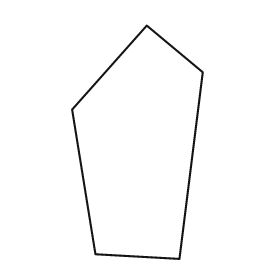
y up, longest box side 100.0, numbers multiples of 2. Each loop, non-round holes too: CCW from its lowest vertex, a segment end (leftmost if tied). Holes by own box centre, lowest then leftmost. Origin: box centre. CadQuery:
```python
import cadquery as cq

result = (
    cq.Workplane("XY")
    .moveTo(18.0, -50.0)
    .lineTo(28.0, 30.0)
    .lineTo(4.0, 50.0)
    .lineTo(-28.0, 14.0)
    .lineTo(-18.0, -48.0)
    .close()
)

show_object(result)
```